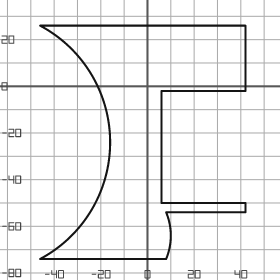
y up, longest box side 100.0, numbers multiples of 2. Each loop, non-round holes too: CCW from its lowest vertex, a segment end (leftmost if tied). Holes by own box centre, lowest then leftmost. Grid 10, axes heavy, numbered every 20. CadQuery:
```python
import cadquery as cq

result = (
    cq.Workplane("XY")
    .moveTo(-46.0, -74.0)
    .lineTo(8.0, -74.0)
    .threePointArc((10.0, -64.0), (8.0, -54.0))
    .lineTo(42.0, -54.0)
    .lineTo(42.0, -50.0)
    .lineTo(6.0, -50.0)
    .lineTo(6.0, -2.0)
    .lineTo(42.0, -2.0)
    .lineTo(42.0, 26.0)
    .lineTo(-46.0, 26.0)
    .threePointArc((-16.0, -24.0), (-46.0, -74.0))
    .close()
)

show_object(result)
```